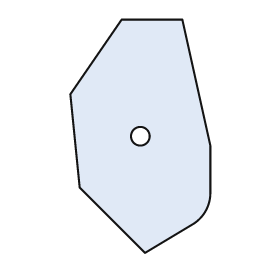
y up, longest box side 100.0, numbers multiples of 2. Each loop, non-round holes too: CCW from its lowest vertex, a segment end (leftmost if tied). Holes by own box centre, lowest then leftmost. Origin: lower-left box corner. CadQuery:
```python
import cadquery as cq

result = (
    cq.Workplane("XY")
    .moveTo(32.0, 0.0)
    .lineTo(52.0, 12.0)
    .threePointArc((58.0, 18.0), (60.0, 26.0))
    .lineTo(60.0, 46.0)
    .lineTo(48.0, 100.0)
    .lineTo(22.0, 100.0)
    .lineTo(0.0, 68.0)
    .lineTo(4.0, 28.0)
    .close()
    .moveTo(30.0, 50.0)
    .circle(4.0)
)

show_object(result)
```